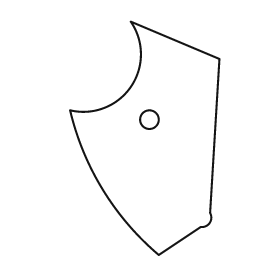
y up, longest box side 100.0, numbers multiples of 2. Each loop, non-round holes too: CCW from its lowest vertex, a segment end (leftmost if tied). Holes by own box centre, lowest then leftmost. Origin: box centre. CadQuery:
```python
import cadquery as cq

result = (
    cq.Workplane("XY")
    .moveTo(6.0, -50.0)
    .lineTo(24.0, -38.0)
    .threePointArc((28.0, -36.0), (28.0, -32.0))
    .lineTo(32.0, 34.0)
    .lineTo(-6.0, 50.0)
    .threePointArc((-6.0, 22.0), (-32.0, 12.0))
    .threePointArc((-18.0, -22.0), (6.0, -50.0))
    .close()
    .moveTo(2.0, 8.0)
    .circle(4.0)
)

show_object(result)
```